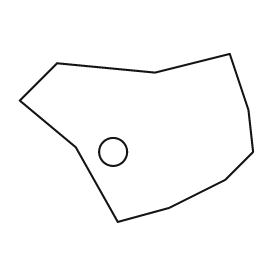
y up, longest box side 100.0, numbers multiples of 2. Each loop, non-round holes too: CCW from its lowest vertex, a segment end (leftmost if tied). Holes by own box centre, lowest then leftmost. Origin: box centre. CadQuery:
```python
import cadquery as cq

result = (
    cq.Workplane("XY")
    .moveTo(-8.0, -36.0)
    .lineTo(14.0, -30.0)
    .lineTo(38.0, -18.0)
    .lineTo(50.0, -6.0)
    .lineTo(48.0, 12.0)
    .lineTo(40.0, 36.0)
    .lineTo(8.0, 28.0)
    .lineTo(-34.0, 32.0)
    .lineTo(-50.0, 16.0)
    .lineTo(-26.0, -4.0)
    .close()
    .moveTo(-10.0, -6.0)
    .circle(6.0)
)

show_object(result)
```